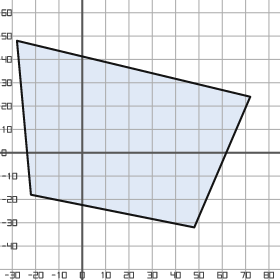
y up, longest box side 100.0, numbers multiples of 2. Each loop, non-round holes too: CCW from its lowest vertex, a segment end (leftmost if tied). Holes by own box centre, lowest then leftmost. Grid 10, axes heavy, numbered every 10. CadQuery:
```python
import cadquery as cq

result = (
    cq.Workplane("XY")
    .moveTo(48.0, -32.0)
    .lineTo(72.0, 24.0)
    .lineTo(-28.0, 48.0)
    .lineTo(-22.0, -18.0)
    .close()
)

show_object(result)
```